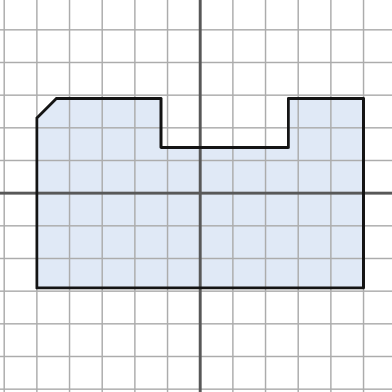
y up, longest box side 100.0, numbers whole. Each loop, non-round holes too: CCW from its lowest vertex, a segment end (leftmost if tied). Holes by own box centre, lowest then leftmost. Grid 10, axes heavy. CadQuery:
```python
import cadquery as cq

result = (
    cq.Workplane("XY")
    .moveTo(-50.0, -29.0)
    .lineTo(50.0, -29.0)
    .lineTo(50.0, 29.0)
    .lineTo(27.0, 29.0)
    .lineTo(27.0, 14.0)
    .lineTo(-12.0, 14.0)
    .lineTo(-12.0, 29.0)
    .lineTo(-44.0, 29.0)
    .lineTo(-50.0, 23.0)
    .close()
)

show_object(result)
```